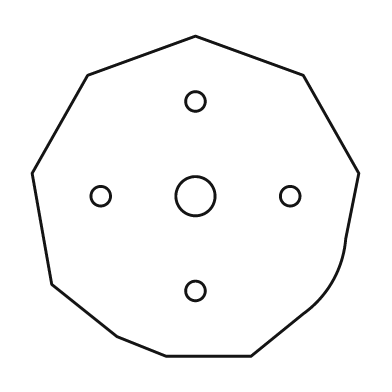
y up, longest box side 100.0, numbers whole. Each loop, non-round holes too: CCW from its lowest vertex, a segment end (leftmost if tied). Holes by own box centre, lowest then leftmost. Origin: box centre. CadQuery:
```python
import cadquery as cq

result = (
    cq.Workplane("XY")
    .moveTo(-9.0, -49.0)
    .lineTo(17.0, -49.0)
    .lineTo(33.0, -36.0)
    .threePointArc((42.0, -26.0), (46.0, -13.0))
    .lineTo(50.0, 7.0)
    .lineTo(33.0, 37.0)
    .lineTo(0.0, 49.0)
    .lineTo(-33.0, 37.0)
    .lineTo(-50.0, 7.0)
    .lineTo(-44.0, -27.0)
    .lineTo(-24.0, -43.0)
    .close()
    .moveTo(0.0, -29.0)
    .circle(3.0)
    .moveTo(-29.0, 0.0)
    .circle(3.0)
    .moveTo(0.0, 0.0)
    .circle(6.0)
    .moveTo(29.0, 0.0)
    .circle(3.0)
    .moveTo(0.0, 29.0)
    .circle(3.0)
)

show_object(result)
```